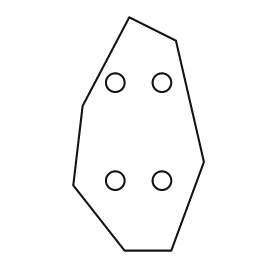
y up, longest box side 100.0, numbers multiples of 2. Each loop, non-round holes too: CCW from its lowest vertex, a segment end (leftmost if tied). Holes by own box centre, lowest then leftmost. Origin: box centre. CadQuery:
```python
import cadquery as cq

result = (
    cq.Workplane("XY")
    .moveTo(-6.0, -50.0)
    .lineTo(14.0, -50.0)
    .lineTo(28.0, -12.0)
    .lineTo(16.0, 40.0)
    .lineTo(-4.0, 50.0)
    .lineTo(-24.0, 12.0)
    .lineTo(-28.0, -22.0)
    .close()
    .moveTo(-10.0, -20.0)
    .circle(4.0)
    .moveTo(10.0, -20.0)
    .circle(4.0)
    .moveTo(-10.0, 22.0)
    .circle(4.0)
    .moveTo(10.0, 22.0)
    .circle(4.0)
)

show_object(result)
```